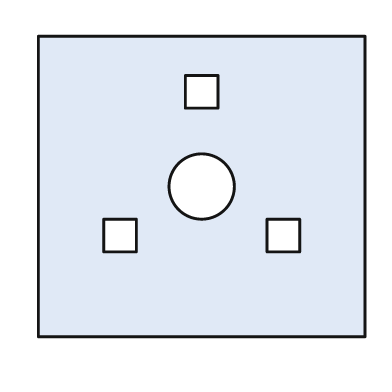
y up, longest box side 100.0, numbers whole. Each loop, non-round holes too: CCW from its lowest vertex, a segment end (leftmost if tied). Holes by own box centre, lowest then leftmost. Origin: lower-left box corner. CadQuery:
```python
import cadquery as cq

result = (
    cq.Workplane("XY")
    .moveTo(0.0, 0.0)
    .lineTo(100.0, 0.0)
    .lineTo(100.0, 92.0)
    .lineTo(0.0, 92.0)
    .close()
    .moveTo(20.0, 26.0)
    .lineTo(30.0, 26.0)
    .lineTo(30.0, 36.0)
    .lineTo(20.0, 36.0)
    .close()
    .moveTo(70.0, 26.0)
    .lineTo(80.0, 26.0)
    .lineTo(80.0, 36.0)
    .lineTo(70.0, 36.0)
    .close()
    .moveTo(50.0, 46.0)
    .circle(10.0)
    .moveTo(45.0, 70.0)
    .lineTo(55.0, 70.0)
    .lineTo(55.0, 80.0)
    .lineTo(45.0, 80.0)
    .close()
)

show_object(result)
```